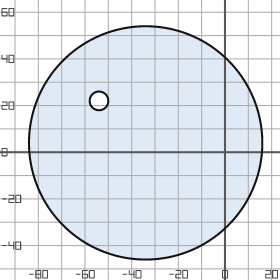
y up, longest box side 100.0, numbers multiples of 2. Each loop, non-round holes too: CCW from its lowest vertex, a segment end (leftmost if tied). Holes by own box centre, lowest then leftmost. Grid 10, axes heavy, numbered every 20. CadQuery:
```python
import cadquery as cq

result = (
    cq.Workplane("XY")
    .moveTo(-34.0, 4.0)
    .circle(50.0)
    .moveTo(-54.0, 22.0)
    .circle(4.0)
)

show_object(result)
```